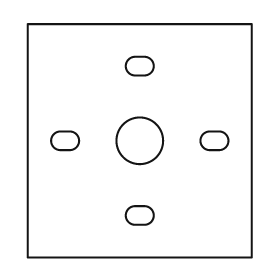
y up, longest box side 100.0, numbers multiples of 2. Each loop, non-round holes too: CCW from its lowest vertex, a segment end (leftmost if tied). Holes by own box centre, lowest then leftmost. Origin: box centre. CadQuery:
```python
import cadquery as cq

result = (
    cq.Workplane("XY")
    .moveTo(-48.0, -50.0)
    .lineTo(48.0, -50.0)
    .lineTo(48.0, 50.0)
    .lineTo(-48.0, 50.0)
    .close()
    .moveTo(-2.0, -36.0)
    .lineTo(2.0, -36.0)
    .threePointArc((6.0, -32.0), (2.0, -28.0))
    .lineTo(-2.0, -28.0)
    .threePointArc((-6.0, -32.0), (-2.0, -36.0))
    .close()
    .moveTo(-34.0, -4.0)
    .lineTo(-30.0, -4.0)
    .threePointArc((-26.0, 0.0), (-30.0, 4.0))
    .lineTo(-34.0, 4.0)
    .threePointArc((-38.0, 0.0), (-34.0, -4.0))
    .close()
    .moveTo(0.0, 0.0)
    .circle(10.0)
    .moveTo(30.0, -4.0)
    .lineTo(34.0, -4.0)
    .threePointArc((38.0, 0.0), (34.0, 4.0))
    .lineTo(30.0, 4.0)
    .threePointArc((26.0, 0.0), (30.0, -4.0))
    .close()
    .moveTo(-2.0, 28.0)
    .lineTo(2.0, 28.0)
    .threePointArc((6.0, 32.0), (2.0, 36.0))
    .lineTo(-2.0, 36.0)
    .threePointArc((-6.0, 32.0), (-2.0, 28.0))
    .close()
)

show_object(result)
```